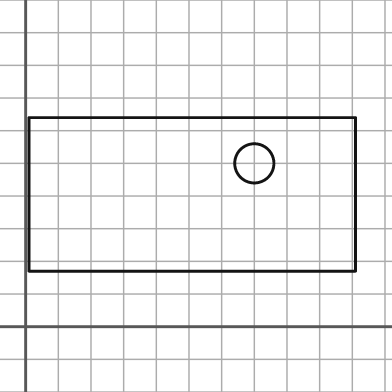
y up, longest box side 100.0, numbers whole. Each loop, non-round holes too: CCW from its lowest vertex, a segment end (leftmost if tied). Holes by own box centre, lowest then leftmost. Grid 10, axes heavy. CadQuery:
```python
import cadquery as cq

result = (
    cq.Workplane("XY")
    .moveTo(1.0, 17.0)
    .lineTo(101.0, 17.0)
    .lineTo(101.0, 64.0)
    .lineTo(1.0, 64.0)
    .close()
    .moveTo(70.0, 50.0)
    .circle(6.0)
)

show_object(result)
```